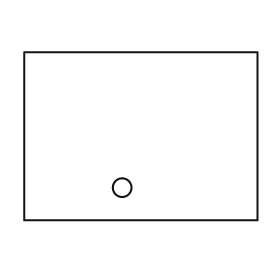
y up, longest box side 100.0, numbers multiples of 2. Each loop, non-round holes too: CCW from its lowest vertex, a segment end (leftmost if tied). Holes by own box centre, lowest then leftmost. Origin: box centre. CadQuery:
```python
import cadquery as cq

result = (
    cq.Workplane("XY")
    .moveTo(-50.0, -36.0)
    .lineTo(50.0, -36.0)
    .lineTo(50.0, 36.0)
    .lineTo(-50.0, 36.0)
    .close()
    .moveTo(-8.0, -22.0)
    .circle(4.0)
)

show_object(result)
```